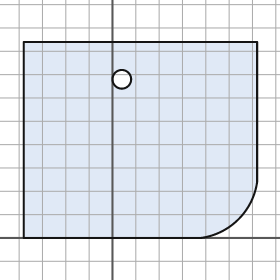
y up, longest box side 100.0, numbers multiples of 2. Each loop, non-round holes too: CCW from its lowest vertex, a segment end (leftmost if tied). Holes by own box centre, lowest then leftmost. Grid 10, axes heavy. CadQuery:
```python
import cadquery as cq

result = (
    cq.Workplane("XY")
    .moveTo(-38.0, 0.0)
    .lineTo(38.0, 0.0)
    .threePointArc((54.0, 8.0), (62.0, 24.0))
    .lineTo(62.0, 84.0)
    .lineTo(-38.0, 84.0)
    .close()
    .moveTo(4.0, 68.0)
    .circle(4.0)
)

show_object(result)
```